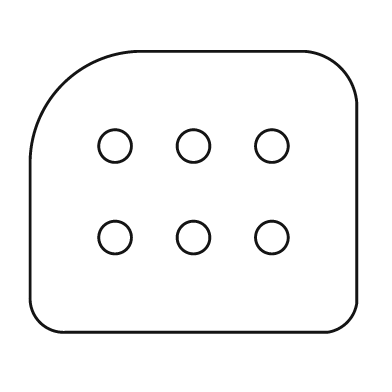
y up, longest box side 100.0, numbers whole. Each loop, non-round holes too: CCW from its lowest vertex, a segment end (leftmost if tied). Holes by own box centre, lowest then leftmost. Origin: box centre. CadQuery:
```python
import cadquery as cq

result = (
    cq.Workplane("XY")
    .moveTo(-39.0, -43.0)
    .lineTo(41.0, -43.0)
    .threePointArc((47.0, -40.0), (50.0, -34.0))
    .lineTo(50.0, 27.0)
    .threePointArc((45.0, 38.0), (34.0, 43.0))
    .lineTo(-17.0, 43.0)
    .threePointArc((-40.0, 33.0), (-50.0, 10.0))
    .lineTo(-50.0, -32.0)
    .threePointArc((-47.0, -40.0), (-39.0, -43.0))
    .close()
    .moveTo(-24.0, -14.0)
    .circle(5.0)
    .moveTo(0.0, -14.0)
    .circle(5.0)
    .moveTo(24.0, -14.0)
    .circle(5.0)
    .moveTo(-24.0, 14.0)
    .circle(5.0)
    .moveTo(0.0, 14.0)
    .circle(5.0)
    .moveTo(24.0, 14.0)
    .circle(5.0)
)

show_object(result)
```